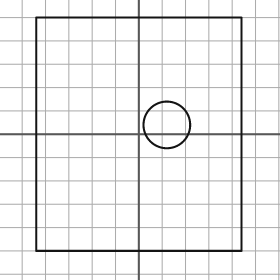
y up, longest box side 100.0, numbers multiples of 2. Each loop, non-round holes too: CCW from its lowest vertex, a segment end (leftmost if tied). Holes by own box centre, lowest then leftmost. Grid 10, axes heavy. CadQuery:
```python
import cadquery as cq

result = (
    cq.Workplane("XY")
    .moveTo(-44.0, -50.0)
    .lineTo(44.0, -50.0)
    .lineTo(44.0, 50.0)
    .lineTo(-44.0, 50.0)
    .close()
    .moveTo(12.0, 4.0)
    .circle(10.0)
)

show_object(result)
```